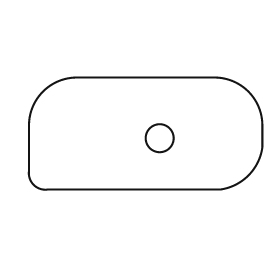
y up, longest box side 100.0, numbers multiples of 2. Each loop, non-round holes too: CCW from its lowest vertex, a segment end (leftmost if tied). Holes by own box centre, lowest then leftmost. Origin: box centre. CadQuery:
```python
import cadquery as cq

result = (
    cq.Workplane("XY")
    .moveTo(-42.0, -24.0)
    .lineTo(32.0, -24.0)
    .threePointArc((44.0, -18.0), (50.0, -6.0))
    .lineTo(50.0, 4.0)
    .threePointArc((44.0, 18.0), (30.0, 24.0))
    .lineTo(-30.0, 24.0)
    .threePointArc((-44.0, 18.0), (-50.0, 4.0))
    .lineTo(-50.0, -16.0)
    .threePointArc((-48.0, -22.0), (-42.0, -24.0))
    .close()
    .moveTo(6.0, -2.0)
    .circle(6.0)
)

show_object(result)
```